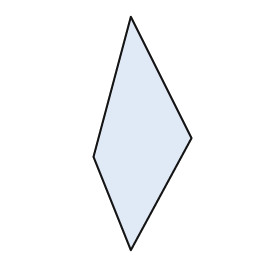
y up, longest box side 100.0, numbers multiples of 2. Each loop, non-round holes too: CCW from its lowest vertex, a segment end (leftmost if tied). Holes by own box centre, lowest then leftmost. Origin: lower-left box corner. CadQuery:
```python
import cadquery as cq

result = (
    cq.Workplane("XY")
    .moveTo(16.0, 0.0)
    .lineTo(42.0, 48.0)
    .lineTo(16.0, 100.0)
    .lineTo(0.0, 40.0)
    .close()
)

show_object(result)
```